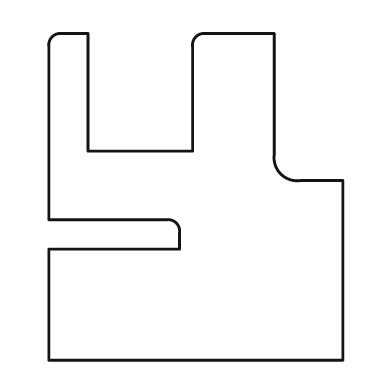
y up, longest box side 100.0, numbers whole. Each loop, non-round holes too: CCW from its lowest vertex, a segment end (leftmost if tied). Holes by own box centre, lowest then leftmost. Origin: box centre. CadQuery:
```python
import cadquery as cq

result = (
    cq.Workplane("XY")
    .moveTo(-45.0, -50.0)
    .lineTo(45.0, -50.0)
    .lineTo(45.0, 5.0)
    .lineTo(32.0, 5.0)
    .threePointArc((26.0, 7.0), (24.0, 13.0))
    .lineTo(24.0, 50.0)
    .lineTo(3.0, 50.0)
    .threePointArc((0.0, 49.0), (-1.0, 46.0))
    .lineTo(-1.0, 14.0)
    .lineTo(-33.0, 14.0)
    .lineTo(-33.0, 50.0)
    .lineTo(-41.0, 50.0)
    .threePointArc((-44.0, 49.0), (-45.0, 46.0))
    .lineTo(-45.0, -7.0)
    .lineTo(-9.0, -7.0)
    .threePointArc((-6.0, -8.0), (-5.0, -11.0))
    .lineTo(-5.0, -16.0)
    .lineTo(-45.0, -16.0)
    .close()
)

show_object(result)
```